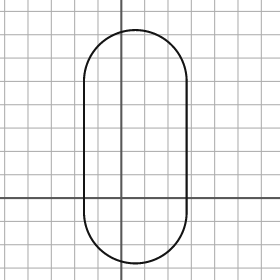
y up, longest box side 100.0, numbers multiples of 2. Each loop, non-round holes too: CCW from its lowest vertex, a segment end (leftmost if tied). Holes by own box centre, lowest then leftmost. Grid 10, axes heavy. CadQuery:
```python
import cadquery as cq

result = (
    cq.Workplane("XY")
    .moveTo(-16.0, -6.0)
    .threePointArc((6.0, -28.0), (28.0, -6.0))
    .lineTo(28.0, 50.0)
    .threePointArc((6.0, 72.0), (-16.0, 50.0))
    .close()
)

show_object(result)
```